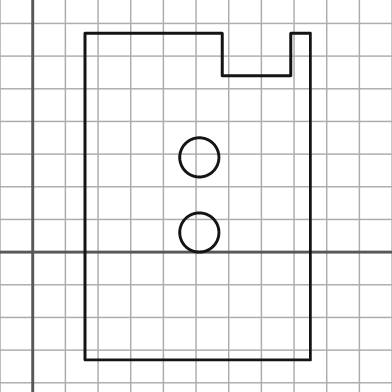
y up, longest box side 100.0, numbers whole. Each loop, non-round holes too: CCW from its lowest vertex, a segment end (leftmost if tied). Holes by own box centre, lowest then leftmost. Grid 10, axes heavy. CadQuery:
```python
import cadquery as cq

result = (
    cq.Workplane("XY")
    .moveTo(16.0, -33.0)
    .lineTo(85.0, -33.0)
    .lineTo(85.0, 67.0)
    .lineTo(79.0, 67.0)
    .lineTo(79.0, 54.0)
    .lineTo(58.0, 54.0)
    .lineTo(58.0, 67.0)
    .lineTo(16.0, 67.0)
    .close()
    .moveTo(51.0, 6.0)
    .circle(6.0)
    .moveTo(51.0, 29.0)
    .circle(6.0)
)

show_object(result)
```